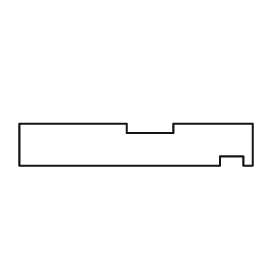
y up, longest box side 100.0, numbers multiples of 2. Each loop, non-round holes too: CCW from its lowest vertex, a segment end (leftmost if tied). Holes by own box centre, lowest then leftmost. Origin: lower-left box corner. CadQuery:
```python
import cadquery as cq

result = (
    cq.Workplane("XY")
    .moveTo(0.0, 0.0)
    .lineTo(86.0, 0.0)
    .lineTo(86.0, 4.0)
    .lineTo(96.0, 4.0)
    .lineTo(96.0, 0.0)
    .lineTo(100.0, 0.0)
    .lineTo(100.0, 18.0)
    .lineTo(66.0, 18.0)
    .lineTo(66.0, 14.0)
    .lineTo(46.0, 14.0)
    .lineTo(46.0, 18.0)
    .lineTo(0.0, 18.0)
    .close()
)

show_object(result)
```